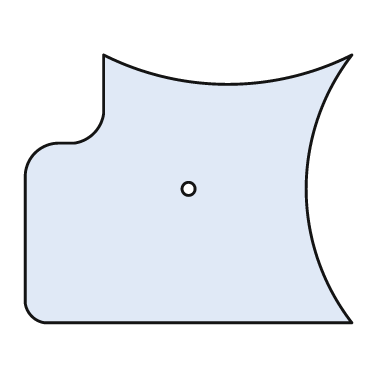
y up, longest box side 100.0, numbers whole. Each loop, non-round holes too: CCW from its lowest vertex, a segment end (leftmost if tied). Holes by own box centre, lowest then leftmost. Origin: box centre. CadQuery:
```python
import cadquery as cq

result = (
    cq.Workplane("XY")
    .moveTo(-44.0, -41.0)
    .lineTo(50.0, -41.0)
    .threePointArc((36.0, 0.0), (50.0, 41.0))
    .threePointArc((12.0, 32.0), (-26.0, 41.0))
    .lineTo(-26.0, 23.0)
    .threePointArc((-29.0, 17.0), (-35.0, 14.0))
    .lineTo(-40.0, 14.0)
    .threePointArc((-47.0, 11.0), (-50.0, 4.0))
    .lineTo(-50.0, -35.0)
    .threePointArc((-48.0, -39.0), (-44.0, -41.0))
    .close()
    .moveTo(0.0, 0.0)
    .circle(2.0)
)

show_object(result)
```